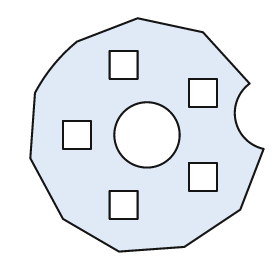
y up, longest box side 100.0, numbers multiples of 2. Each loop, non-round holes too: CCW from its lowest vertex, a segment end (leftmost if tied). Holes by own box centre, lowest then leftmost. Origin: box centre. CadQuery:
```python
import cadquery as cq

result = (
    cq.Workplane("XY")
    .moveTo(-12.0, -50.0)
    .lineTo(16.0, -48.0)
    .lineTo(40.0, -32.0)
    .lineTo(50.0, -6.0)
    .threePointArc((38.0, 6.0), (44.0, 22.0))
    .lineTo(24.0, 44.0)
    .lineTo(-4.0, 50.0)
    .lineTo(-30.0, 40.0)
    .threePointArc((-40.0, 30.0), (-48.0, 18.0))
    .lineTo(-50.0, -10.0)
    .lineTo(-36.0, -36.0)
    .close()
    .moveTo(-16.0, -36.0)
    .lineTo(-4.0, -36.0)
    .lineTo(-4.0, -24.0)
    .lineTo(-16.0, -24.0)
    .close()
    .moveTo(18.0, -24.0)
    .lineTo(30.0, -24.0)
    .lineTo(30.0, -12.0)
    .lineTo(18.0, -12.0)
    .close()
    .moveTo(-36.0, -6.0)
    .lineTo(-24.0, -6.0)
    .lineTo(-24.0, 6.0)
    .lineTo(-36.0, 6.0)
    .close()
    .moveTo(0.0, 0.0)
    .circle(14.0)
    .moveTo(18.0, 12.0)
    .lineTo(30.0, 12.0)
    .lineTo(30.0, 24.0)
    .lineTo(18.0, 24.0)
    .close()
    .moveTo(-16.0, 24.0)
    .lineTo(-4.0, 24.0)
    .lineTo(-4.0, 36.0)
    .lineTo(-16.0, 36.0)
    .close()
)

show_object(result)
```